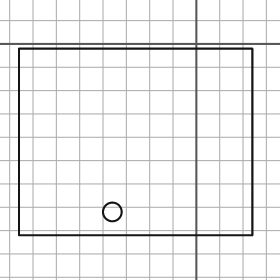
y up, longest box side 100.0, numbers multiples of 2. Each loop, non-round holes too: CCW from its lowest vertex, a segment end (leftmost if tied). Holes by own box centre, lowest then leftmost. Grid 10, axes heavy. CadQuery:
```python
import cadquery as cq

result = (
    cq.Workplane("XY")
    .moveTo(-76.0, -82.0)
    .lineTo(24.0, -82.0)
    .lineTo(24.0, -2.0)
    .lineTo(-76.0, -2.0)
    .close()
    .moveTo(-36.0, -72.0)
    .circle(4.0)
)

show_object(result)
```